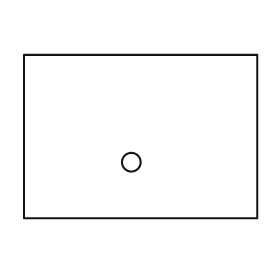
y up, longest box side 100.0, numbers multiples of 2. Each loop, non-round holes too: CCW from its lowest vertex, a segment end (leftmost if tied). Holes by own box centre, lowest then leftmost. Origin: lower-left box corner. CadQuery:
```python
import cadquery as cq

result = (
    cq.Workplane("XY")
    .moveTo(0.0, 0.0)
    .lineTo(100.0, 0.0)
    .lineTo(100.0, 70.0)
    .lineTo(0.0, 70.0)
    .close()
    .moveTo(46.0, 24.0)
    .circle(4.0)
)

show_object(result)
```